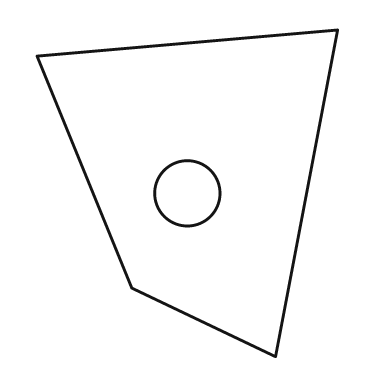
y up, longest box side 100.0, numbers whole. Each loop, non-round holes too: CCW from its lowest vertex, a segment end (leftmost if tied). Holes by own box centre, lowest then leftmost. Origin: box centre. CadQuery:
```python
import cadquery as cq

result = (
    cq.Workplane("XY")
    .moveTo(27.0, -50.0)
    .lineTo(46.0, 50.0)
    .lineTo(-46.0, 42.0)
    .lineTo(-17.0, -29.0)
    .close()
    .moveTo(0.0, 0.0)
    .circle(10.0)
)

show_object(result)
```